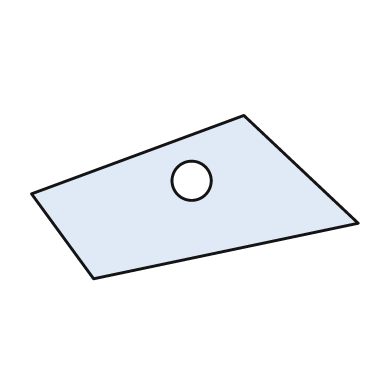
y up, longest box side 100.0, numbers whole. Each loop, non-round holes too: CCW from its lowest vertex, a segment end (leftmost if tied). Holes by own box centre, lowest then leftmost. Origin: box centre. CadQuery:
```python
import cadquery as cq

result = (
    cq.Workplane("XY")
    .moveTo(-31.0, -25.0)
    .lineTo(50.0, -8.0)
    .lineTo(15.0, 25.0)
    .lineTo(-50.0, 1.0)
    .close()
    .moveTo(-1.0, 5.0)
    .circle(6.0)
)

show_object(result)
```